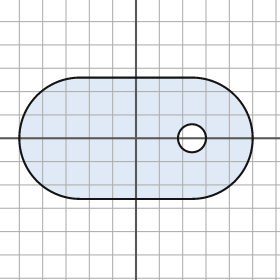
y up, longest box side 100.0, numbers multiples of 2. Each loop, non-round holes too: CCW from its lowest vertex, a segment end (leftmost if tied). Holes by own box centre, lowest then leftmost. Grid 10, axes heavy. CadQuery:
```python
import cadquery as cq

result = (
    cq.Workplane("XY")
    .moveTo(-24.0, -26.0)
    .lineTo(24.0, -26.0)
    .threePointArc((50.0, 0.0), (24.0, 26.0))
    .lineTo(-24.0, 26.0)
    .threePointArc((-50.0, 0.0), (-24.0, -26.0))
    .close()
    .moveTo(24.0, 0.0)
    .circle(6.0)
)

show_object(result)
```